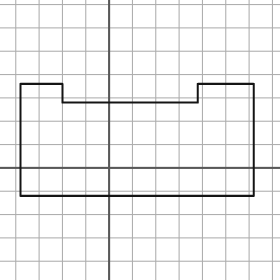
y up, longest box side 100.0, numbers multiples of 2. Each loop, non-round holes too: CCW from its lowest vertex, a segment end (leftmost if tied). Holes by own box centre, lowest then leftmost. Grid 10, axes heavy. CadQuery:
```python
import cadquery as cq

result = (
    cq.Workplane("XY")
    .moveTo(-38.0, -12.0)
    .lineTo(62.0, -12.0)
    .lineTo(62.0, 36.0)
    .lineTo(38.0, 36.0)
    .lineTo(38.0, 28.0)
    .lineTo(-20.0, 28.0)
    .lineTo(-20.0, 36.0)
    .lineTo(-38.0, 36.0)
    .close()
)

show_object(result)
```